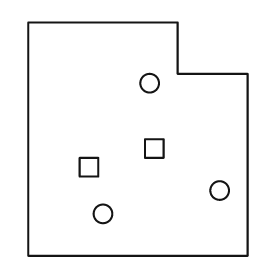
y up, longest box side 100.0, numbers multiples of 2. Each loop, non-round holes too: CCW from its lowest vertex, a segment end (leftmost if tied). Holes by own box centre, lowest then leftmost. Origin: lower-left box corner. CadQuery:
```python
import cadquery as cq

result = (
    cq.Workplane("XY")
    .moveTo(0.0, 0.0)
    .lineTo(94.0, 0.0)
    .lineTo(94.0, 78.0)
    .lineTo(64.0, 78.0)
    .lineTo(64.0, 100.0)
    .lineTo(0.0, 100.0)
    .close()
    .moveTo(32.0, 18.0)
    .circle(4.0)
    .moveTo(82.0, 28.0)
    .circle(4.0)
    .moveTo(22.0, 34.0)
    .lineTo(30.0, 34.0)
    .lineTo(30.0, 42.0)
    .lineTo(22.0, 42.0)
    .close()
    .moveTo(50.0, 42.0)
    .lineTo(58.0, 42.0)
    .lineTo(58.0, 50.0)
    .lineTo(50.0, 50.0)
    .close()
    .moveTo(52.0, 74.0)
    .circle(4.0)
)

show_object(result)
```